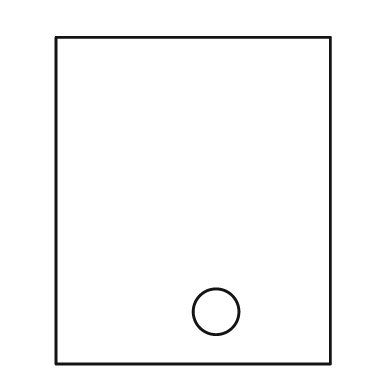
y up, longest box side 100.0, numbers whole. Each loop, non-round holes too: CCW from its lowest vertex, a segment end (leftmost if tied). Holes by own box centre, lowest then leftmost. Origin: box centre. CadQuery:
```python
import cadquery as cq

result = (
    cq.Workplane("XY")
    .moveTo(-42.0, -50.0)
    .lineTo(42.0, -50.0)
    .lineTo(42.0, 50.0)
    .lineTo(-42.0, 50.0)
    .close()
    .moveTo(7.0, -34.0)
    .circle(7.0)
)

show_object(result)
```